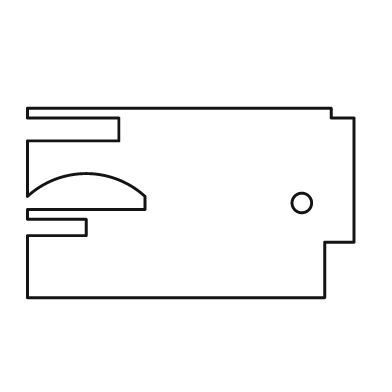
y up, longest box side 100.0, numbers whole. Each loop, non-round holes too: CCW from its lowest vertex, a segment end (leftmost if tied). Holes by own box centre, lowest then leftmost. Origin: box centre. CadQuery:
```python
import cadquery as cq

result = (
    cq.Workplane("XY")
    .moveTo(-50.0, -29.0)
    .lineTo(41.0, -29.0)
    .lineTo(41.0, -12.0)
    .lineTo(50.0, -12.0)
    .lineTo(50.0, 26.0)
    .lineTo(43.0, 26.0)
    .lineTo(43.0, 29.0)
    .lineTo(-50.0, 29.0)
    .lineTo(-50.0, 26.0)
    .lineTo(-22.0, 26.0)
    .lineTo(-22.0, 19.0)
    .lineTo(-50.0, 19.0)
    .lineTo(-50.0, 2.0)
    .threePointArc((-32.0, 9.0), (-14.0, 2.0))
    .lineTo(-14.0, -2.0)
    .lineTo(-50.0, -2.0)
    .lineTo(-50.0, -5.0)
    .lineTo(-32.0, -5.0)
    .lineTo(-32.0, -10.0)
    .lineTo(-50.0, -10.0)
    .close()
    .moveTo(34.0, 0.0)
    .circle(3.0)
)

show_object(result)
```